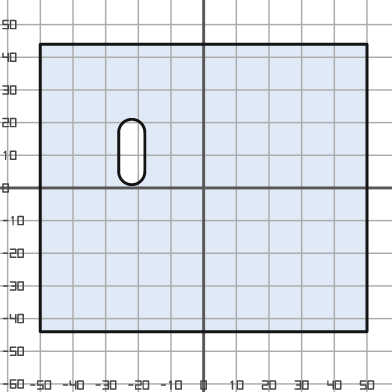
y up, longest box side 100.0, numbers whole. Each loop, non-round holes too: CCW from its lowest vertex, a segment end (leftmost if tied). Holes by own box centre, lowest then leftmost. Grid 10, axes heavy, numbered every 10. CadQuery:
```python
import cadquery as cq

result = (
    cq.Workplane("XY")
    .moveTo(-50.0, -44.0)
    .lineTo(50.0, -44.0)
    .lineTo(50.0, 44.0)
    .lineTo(-50.0, 44.0)
    .close()
    .moveTo(-26.0, 5.0)
    .threePointArc((-22.0, 1.0), (-18.0, 5.0))
    .lineTo(-18.0, 17.0)
    .threePointArc((-22.0, 21.0), (-26.0, 17.0))
    .close()
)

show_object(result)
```